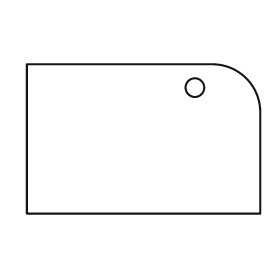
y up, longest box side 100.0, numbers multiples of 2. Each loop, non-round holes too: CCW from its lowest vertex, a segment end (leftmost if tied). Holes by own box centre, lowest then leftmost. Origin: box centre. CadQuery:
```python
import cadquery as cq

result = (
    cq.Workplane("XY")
    .moveTo(-50.0, -32.0)
    .lineTo(50.0, -32.0)
    .lineTo(50.0, 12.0)
    .threePointArc((44.0, 26.0), (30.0, 32.0))
    .lineTo(-50.0, 32.0)
    .close()
    .moveTo(22.0, 22.0)
    .circle(4.0)
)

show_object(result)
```